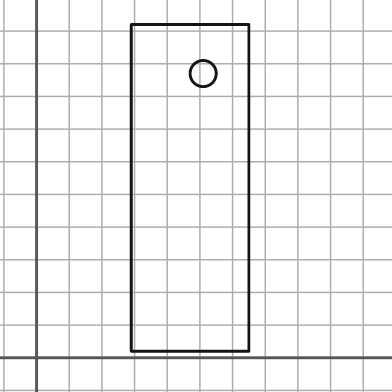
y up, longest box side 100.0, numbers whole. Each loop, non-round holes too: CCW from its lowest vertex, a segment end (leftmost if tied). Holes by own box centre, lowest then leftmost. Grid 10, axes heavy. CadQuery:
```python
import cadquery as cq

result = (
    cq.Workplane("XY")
    .moveTo(29.0, 2.0)
    .lineTo(65.0, 2.0)
    .lineTo(65.0, 102.0)
    .lineTo(29.0, 102.0)
    .close()
    .moveTo(51.0, 87.0)
    .circle(4.0)
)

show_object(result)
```